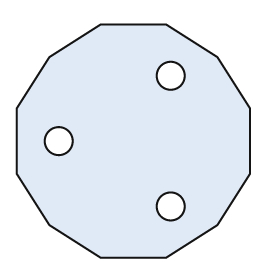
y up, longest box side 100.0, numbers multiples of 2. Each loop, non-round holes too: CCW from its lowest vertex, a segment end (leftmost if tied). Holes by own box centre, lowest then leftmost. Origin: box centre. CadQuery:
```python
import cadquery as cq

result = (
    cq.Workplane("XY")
    .moveTo(-14.0, -50.0)
    .lineTo(14.0, -50.0)
    .lineTo(36.0, -36.0)
    .lineTo(50.0, -14.0)
    .lineTo(50.0, 14.0)
    .lineTo(36.0, 36.0)
    .lineTo(14.0, 50.0)
    .lineTo(-14.0, 50.0)
    .lineTo(-36.0, 36.0)
    .lineTo(-50.0, 14.0)
    .lineTo(-50.0, -14.0)
    .lineTo(-36.0, -36.0)
    .close()
    .moveTo(16.0, -28.0)
    .circle(6.0)
    .moveTo(-32.0, 0.0)
    .circle(6.0)
    .moveTo(16.0, 28.0)
    .circle(6.0)
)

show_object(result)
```